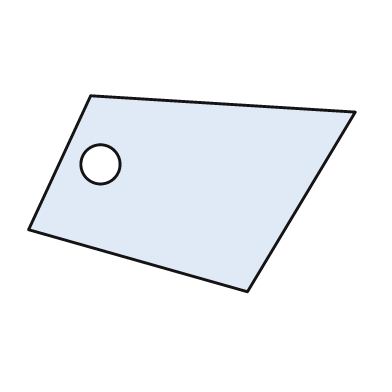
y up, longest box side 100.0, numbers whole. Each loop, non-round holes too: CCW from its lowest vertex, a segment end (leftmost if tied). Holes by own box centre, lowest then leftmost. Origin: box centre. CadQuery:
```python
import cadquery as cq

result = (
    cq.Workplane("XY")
    .moveTo(17.0, -30.0)
    .lineTo(50.0, 25.0)
    .lineTo(-31.0, 30.0)
    .lineTo(-50.0, -11.0)
    .close()
    .moveTo(-28.0, 9.0)
    .circle(6.0)
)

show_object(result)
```